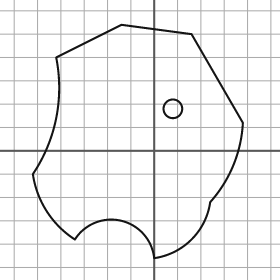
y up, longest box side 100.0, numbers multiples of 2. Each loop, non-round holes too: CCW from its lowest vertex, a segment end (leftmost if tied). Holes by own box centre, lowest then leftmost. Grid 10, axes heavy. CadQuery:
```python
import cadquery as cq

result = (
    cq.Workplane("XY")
    .moveTo(0.0, -46.0)
    .threePointArc((16.0, -38.0), (24.0, -22.0))
    .threePointArc((34.0, -6.0), (38.0, 12.0))
    .lineTo(16.0, 50.0)
    .lineTo(-14.0, 54.0)
    .lineTo(-42.0, 40.0)
    .threePointArc((-42.0, 14.0), (-52.0, -10.0))
    .threePointArc((-46.0, -26.0), (-34.0, -38.0))
    .threePointArc((-14.0, -30.0), (0.0, -46.0))
    .close()
    .moveTo(8.0, 18.0)
    .circle(4.0)
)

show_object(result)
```